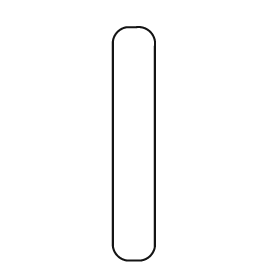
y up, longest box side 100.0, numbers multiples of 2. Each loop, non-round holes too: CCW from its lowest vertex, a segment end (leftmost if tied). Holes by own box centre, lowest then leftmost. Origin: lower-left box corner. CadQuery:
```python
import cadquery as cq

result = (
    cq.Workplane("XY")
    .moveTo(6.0, 0.0)
    .lineTo(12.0, 0.0)
    .threePointArc((16.0, 2.0), (18.0, 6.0))
    .lineTo(18.0, 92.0)
    .threePointArc((16.0, 98.0), (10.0, 100.0))
    .lineTo(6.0, 100.0)
    .threePointArc((2.0, 98.0), (0.0, 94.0))
    .lineTo(0.0, 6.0)
    .threePointArc((2.0, 2.0), (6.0, 0.0))
    .close()
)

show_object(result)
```